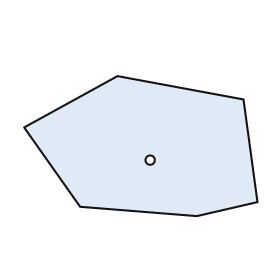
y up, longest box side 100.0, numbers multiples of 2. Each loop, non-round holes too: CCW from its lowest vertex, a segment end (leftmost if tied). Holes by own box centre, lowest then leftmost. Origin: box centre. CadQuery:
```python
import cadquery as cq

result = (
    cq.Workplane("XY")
    .moveTo(24.0, -30.0)
    .lineTo(50.0, -24.0)
    .lineTo(44.0, 20.0)
    .lineTo(-10.0, 30.0)
    .lineTo(-50.0, 8.0)
    .lineTo(-26.0, -26.0)
    .close()
    .moveTo(4.0, -6.0)
    .circle(2.0)
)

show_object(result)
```